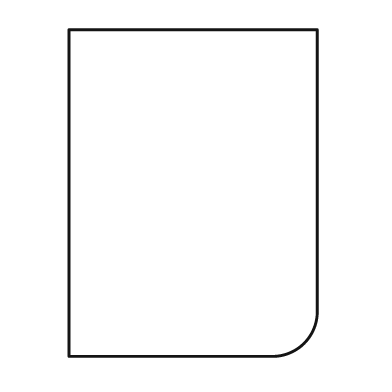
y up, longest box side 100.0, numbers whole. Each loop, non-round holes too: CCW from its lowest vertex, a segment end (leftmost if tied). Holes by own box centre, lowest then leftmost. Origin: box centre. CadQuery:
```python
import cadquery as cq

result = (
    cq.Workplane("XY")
    .moveTo(-38.0, -50.0)
    .lineTo(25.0, -50.0)
    .threePointArc((34.0, -46.0), (38.0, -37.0))
    .lineTo(38.0, 50.0)
    .lineTo(-38.0, 50.0)
    .close()
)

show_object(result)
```